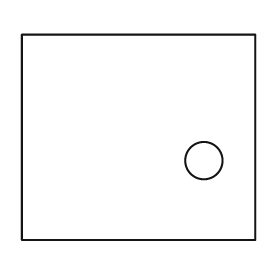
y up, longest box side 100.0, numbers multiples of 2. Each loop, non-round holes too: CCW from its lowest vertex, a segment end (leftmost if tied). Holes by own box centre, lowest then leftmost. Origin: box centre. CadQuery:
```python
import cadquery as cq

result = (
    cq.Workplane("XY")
    .moveTo(-50.0, -44.0)
    .lineTo(50.0, -44.0)
    .lineTo(50.0, 44.0)
    .lineTo(-50.0, 44.0)
    .close()
    .moveTo(28.0, -10.0)
    .circle(8.0)
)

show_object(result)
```